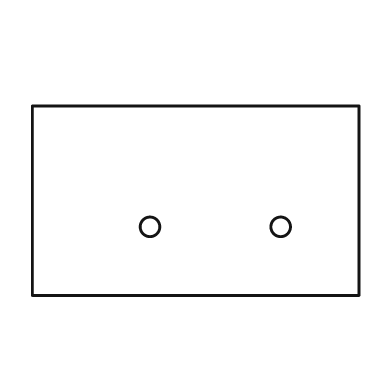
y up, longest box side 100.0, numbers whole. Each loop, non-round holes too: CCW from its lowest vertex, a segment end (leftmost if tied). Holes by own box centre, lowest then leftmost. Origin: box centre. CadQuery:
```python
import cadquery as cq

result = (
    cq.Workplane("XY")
    .moveTo(-50.0, -29.0)
    .lineTo(50.0, -29.0)
    .lineTo(50.0, 29.0)
    .lineTo(-50.0, 29.0)
    .close()
    .moveTo(-14.0, -8.0)
    .circle(3.0)
    .moveTo(26.0, -8.0)
    .circle(3.0)
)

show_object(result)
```